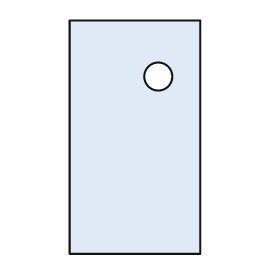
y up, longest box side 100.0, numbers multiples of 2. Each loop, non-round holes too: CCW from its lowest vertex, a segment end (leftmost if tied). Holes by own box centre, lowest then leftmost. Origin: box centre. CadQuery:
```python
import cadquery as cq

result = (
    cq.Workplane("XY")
    .moveTo(-28.0, -50.0)
    .lineTo(28.0, -50.0)
    .lineTo(28.0, 50.0)
    .lineTo(-28.0, 50.0)
    .close()
    .moveTo(10.0, 26.0)
    .circle(6.0)
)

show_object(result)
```